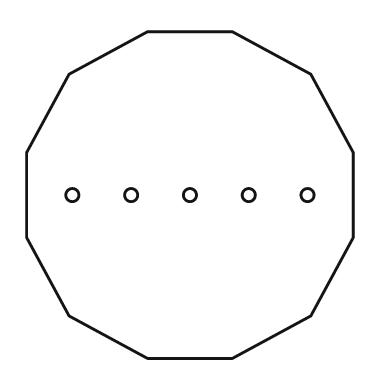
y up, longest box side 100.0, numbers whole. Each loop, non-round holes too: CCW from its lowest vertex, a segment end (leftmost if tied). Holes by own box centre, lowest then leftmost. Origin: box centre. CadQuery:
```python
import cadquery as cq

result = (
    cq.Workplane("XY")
    .moveTo(-13.0, -50.0)
    .lineTo(13.0, -50.0)
    .lineTo(37.0, -37.0)
    .lineTo(50.0, -13.0)
    .lineTo(50.0, 13.0)
    .lineTo(37.0, 37.0)
    .lineTo(13.0, 50.0)
    .lineTo(-13.0, 50.0)
    .lineTo(-37.0, 37.0)
    .lineTo(-50.0, 13.0)
    .lineTo(-50.0, -13.0)
    .lineTo(-37.0, -37.0)
    .close()
    .moveTo(-36.0, 0.0)
    .circle(2.0)
    .moveTo(-18.0, 0.0)
    .circle(2.0)
    .moveTo(0.0, 0.0)
    .circle(2.0)
    .moveTo(18.0, 0.0)
    .circle(2.0)
    .moveTo(36.0, 0.0)
    .circle(2.0)
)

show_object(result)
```